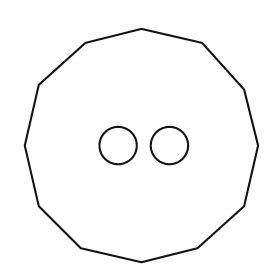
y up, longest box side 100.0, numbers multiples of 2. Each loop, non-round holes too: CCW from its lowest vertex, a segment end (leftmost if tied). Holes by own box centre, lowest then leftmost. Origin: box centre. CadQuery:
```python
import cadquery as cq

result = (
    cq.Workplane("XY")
    .moveTo(0.0, -50.0)
    .lineTo(24.0, -44.0)
    .lineTo(44.0, -26.0)
    .lineTo(50.0, 0.0)
    .lineTo(44.0, 24.0)
    .lineTo(26.0, 44.0)
    .lineTo(0.0, 50.0)
    .lineTo(-24.0, 44.0)
    .lineTo(-44.0, 26.0)
    .lineTo(-50.0, 0.0)
    .lineTo(-44.0, -26.0)
    .lineTo(-26.0, -44.0)
    .close()
    .moveTo(-10.0, 0.0)
    .circle(8.0)
    .moveTo(12.0, 0.0)
    .circle(8.0)
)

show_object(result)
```